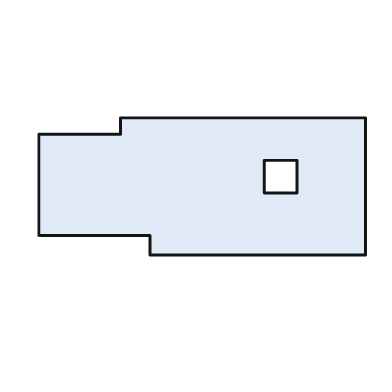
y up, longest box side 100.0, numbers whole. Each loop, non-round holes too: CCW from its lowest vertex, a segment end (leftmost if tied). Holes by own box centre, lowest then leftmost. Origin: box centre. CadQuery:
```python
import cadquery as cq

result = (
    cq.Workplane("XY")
    .moveTo(-16.0, -21.0)
    .lineTo(50.0, -21.0)
    .lineTo(50.0, 21.0)
    .lineTo(-25.0, 21.0)
    .lineTo(-25.0, 16.0)
    .lineTo(-50.0, 16.0)
    .lineTo(-50.0, -15.0)
    .lineTo(-16.0, -15.0)
    .close()
    .moveTo(19.0, -2.0)
    .lineTo(29.0, -2.0)
    .lineTo(29.0, 8.0)
    .lineTo(19.0, 8.0)
    .close()
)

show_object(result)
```